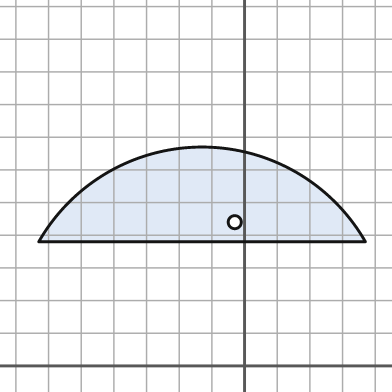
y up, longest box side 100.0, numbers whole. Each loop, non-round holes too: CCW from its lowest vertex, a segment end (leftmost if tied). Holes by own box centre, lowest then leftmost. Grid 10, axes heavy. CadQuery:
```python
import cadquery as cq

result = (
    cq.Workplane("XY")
    .moveTo(-63.0, 38.0)
    .lineTo(37.0, 38.0)
    .threePointArc((-13.0, 67.0), (-63.0, 38.0))
    .close()
    .moveTo(-3.0, 44.0)
    .circle(2.0)
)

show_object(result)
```